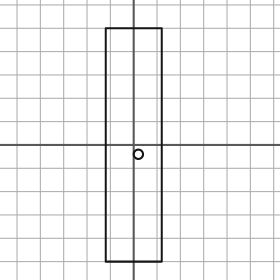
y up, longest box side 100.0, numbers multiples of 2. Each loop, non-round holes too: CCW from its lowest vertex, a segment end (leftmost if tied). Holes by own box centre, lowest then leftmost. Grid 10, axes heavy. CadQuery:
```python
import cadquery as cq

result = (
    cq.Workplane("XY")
    .moveTo(-12.0, -50.0)
    .lineTo(12.0, -50.0)
    .lineTo(12.0, 50.0)
    .lineTo(-12.0, 50.0)
    .close()
    .moveTo(2.0, -4.0)
    .circle(2.0)
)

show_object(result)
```